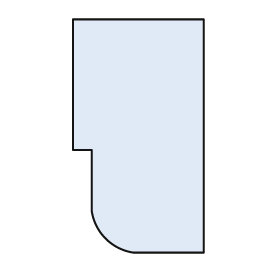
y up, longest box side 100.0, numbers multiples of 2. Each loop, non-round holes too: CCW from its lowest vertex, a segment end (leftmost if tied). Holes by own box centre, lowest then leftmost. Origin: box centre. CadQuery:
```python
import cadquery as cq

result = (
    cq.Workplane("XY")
    .moveTo(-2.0, -50.0)
    .lineTo(28.0, -50.0)
    .lineTo(28.0, 50.0)
    .lineTo(-28.0, 50.0)
    .lineTo(-28.0, -6.0)
    .lineTo(-20.0, -6.0)
    .lineTo(-20.0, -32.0)
    .threePointArc((-14.0, -44.0), (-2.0, -50.0))
    .close()
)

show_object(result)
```